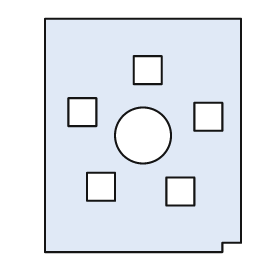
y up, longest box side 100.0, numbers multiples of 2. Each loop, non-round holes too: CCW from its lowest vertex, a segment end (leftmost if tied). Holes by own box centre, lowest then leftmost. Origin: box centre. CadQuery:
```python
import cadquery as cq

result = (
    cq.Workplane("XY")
    .moveTo(-42.0, -50.0)
    .lineTo(34.0, -50.0)
    .lineTo(34.0, -46.0)
    .lineTo(42.0, -46.0)
    .lineTo(42.0, 50.0)
    .lineTo(-42.0, 50.0)
    .close()
    .moveTo(10.0, -30.0)
    .lineTo(22.0, -30.0)
    .lineTo(22.0, -18.0)
    .lineTo(10.0, -18.0)
    .close()
    .moveTo(-24.0, -28.0)
    .lineTo(-12.0, -28.0)
    .lineTo(-12.0, -16.0)
    .lineTo(-24.0, -16.0)
    .close()
    .moveTo(0.0, 0.0)
    .circle(12.0)
    .moveTo(22.0, 2.0)
    .lineTo(34.0, 2.0)
    .lineTo(34.0, 14.0)
    .lineTo(22.0, 14.0)
    .close()
    .moveTo(-32.0, 4.0)
    .lineTo(-20.0, 4.0)
    .lineTo(-20.0, 16.0)
    .lineTo(-32.0, 16.0)
    .close()
    .moveTo(-4.0, 22.0)
    .lineTo(8.0, 22.0)
    .lineTo(8.0, 34.0)
    .lineTo(-4.0, 34.0)
    .close()
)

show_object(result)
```